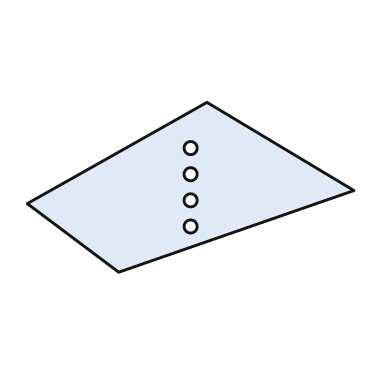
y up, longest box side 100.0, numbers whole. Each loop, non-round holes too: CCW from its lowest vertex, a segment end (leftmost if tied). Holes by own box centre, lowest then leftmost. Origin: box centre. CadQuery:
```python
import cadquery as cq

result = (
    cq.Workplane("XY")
    .moveTo(-22.0, -26.0)
    .lineTo(50.0, -1.0)
    .lineTo(5.0, 26.0)
    .lineTo(-50.0, -5.0)
    .close()
    .moveTo(0.0, -12.0)
    .circle(2.0)
    .moveTo(0.0, -4.0)
    .circle(2.0)
    .moveTo(0.0, 4.0)
    .circle(2.0)
    .moveTo(0.0, 12.0)
    .circle(2.0)
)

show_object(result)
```